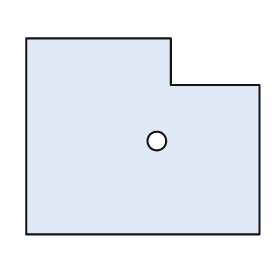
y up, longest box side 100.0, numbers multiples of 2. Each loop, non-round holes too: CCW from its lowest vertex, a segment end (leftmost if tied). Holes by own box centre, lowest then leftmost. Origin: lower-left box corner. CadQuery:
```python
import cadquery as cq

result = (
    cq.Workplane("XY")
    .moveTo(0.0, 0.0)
    .lineTo(100.0, 0.0)
    .lineTo(100.0, 64.0)
    .lineTo(62.0, 64.0)
    .lineTo(62.0, 84.0)
    .lineTo(0.0, 84.0)
    .close()
    .moveTo(56.0, 40.0)
    .circle(4.0)
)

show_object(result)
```